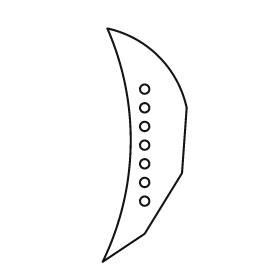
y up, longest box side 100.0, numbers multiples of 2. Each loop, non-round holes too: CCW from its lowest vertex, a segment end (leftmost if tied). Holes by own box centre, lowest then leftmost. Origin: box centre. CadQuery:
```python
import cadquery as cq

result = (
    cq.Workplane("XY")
    .moveTo(-18.0, -50.0)
    .lineTo(0.0, -38.0)
    .lineTo(16.0, -12.0)
    .lineTo(18.0, 16.0)
    .threePointArc((6.0, 38.0), (-16.0, 50.0))
    .threePointArc((-6.0, 0.0), (-18.0, -50.0))
    .close()
    .moveTo(0.0, -24.0)
    .circle(2.0)
    .moveTo(0.0, -16.0)
    .circle(2.0)
    .moveTo(0.0, -8.0)
    .circle(2.0)
    .moveTo(0.0, 0.0)
    .circle(2.0)
    .moveTo(0.0, 8.0)
    .circle(2.0)
    .moveTo(0.0, 16.0)
    .circle(2.0)
    .moveTo(0.0, 24.0)
    .circle(2.0)
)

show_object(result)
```